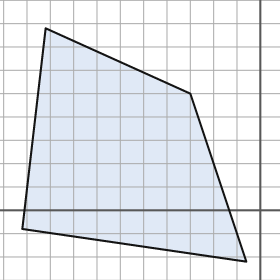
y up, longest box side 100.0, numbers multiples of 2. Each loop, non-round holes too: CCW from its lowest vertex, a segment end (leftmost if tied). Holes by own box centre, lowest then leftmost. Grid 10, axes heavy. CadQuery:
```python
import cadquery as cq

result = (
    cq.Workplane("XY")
    .moveTo(-6.0, -22.0)
    .lineTo(-30.0, 50.0)
    .lineTo(-92.0, 78.0)
    .lineTo(-102.0, -8.0)
    .close()
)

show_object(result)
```